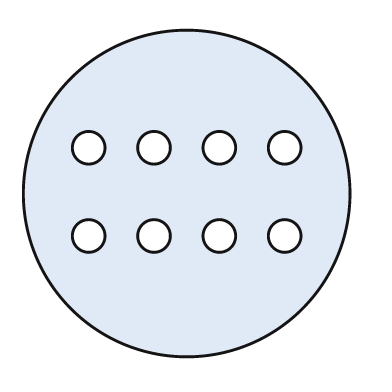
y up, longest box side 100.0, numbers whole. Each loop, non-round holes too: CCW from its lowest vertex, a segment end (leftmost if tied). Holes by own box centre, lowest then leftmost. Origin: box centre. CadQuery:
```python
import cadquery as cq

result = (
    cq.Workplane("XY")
    .moveTo(0.0, 0.0)
    .circle(50.0)
    .moveTo(-30.0, -13.0)
    .circle(5.0)
    .moveTo(-10.0, -13.0)
    .circle(5.0)
    .moveTo(10.0, -13.0)
    .circle(5.0)
    .moveTo(30.0, -13.0)
    .circle(5.0)
    .moveTo(-30.0, 14.0)
    .circle(5.0)
    .moveTo(-10.0, 14.0)
    .circle(5.0)
    .moveTo(10.0, 14.0)
    .circle(5.0)
    .moveTo(30.0, 14.0)
    .circle(5.0)
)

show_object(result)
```